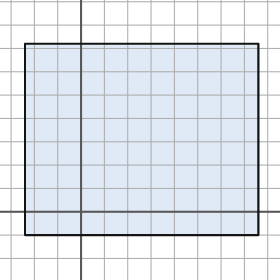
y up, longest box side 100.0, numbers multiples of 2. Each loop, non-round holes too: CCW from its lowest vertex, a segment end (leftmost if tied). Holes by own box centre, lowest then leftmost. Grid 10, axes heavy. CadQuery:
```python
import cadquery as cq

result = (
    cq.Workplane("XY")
    .moveTo(-24.0, -10.0)
    .lineTo(76.0, -10.0)
    .lineTo(76.0, 72.0)
    .lineTo(-24.0, 72.0)
    .close()
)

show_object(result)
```